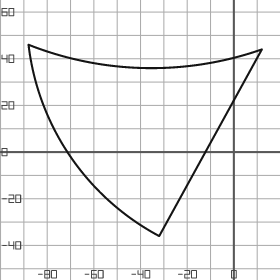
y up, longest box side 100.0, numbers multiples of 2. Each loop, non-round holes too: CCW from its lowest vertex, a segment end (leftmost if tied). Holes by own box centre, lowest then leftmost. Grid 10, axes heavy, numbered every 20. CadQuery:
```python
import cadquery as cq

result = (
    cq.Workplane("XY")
    .moveTo(-32.0, -36.0)
    .lineTo(12.0, 44.0)
    .threePointArc((-38.0, 36.0), (-88.0, 46.0))
    .threePointArc((-70.0, -2.0), (-32.0, -36.0))
    .close()
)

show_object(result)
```